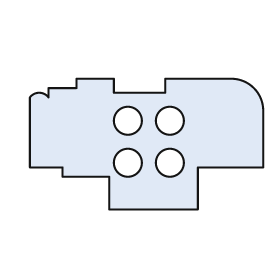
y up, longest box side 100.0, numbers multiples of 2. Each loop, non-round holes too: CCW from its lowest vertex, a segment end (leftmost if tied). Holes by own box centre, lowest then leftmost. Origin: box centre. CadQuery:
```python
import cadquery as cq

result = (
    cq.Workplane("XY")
    .moveTo(-16.0, -28.0)
    .lineTo(22.0, -28.0)
    .lineTo(22.0, -10.0)
    .lineTo(50.0, -10.0)
    .lineTo(50.0, 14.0)
    .threePointArc((46.0, 24.0), (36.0, 28.0))
    .lineTo(8.0, 28.0)
    .lineTo(8.0, 22.0)
    .lineTo(-14.0, 22.0)
    .lineTo(-14.0, 28.0)
    .lineTo(-30.0, 28.0)
    .lineTo(-30.0, 24.0)
    .lineTo(-42.0, 24.0)
    .lineTo(-42.0, 20.0)
    .threePointArc((-46.0, 22.0), (-50.0, 20.0))
    .lineTo(-50.0, -10.0)
    .lineTo(-36.0, -10.0)
    .lineTo(-36.0, -14.0)
    .lineTo(-16.0, -14.0)
    .close()
    .moveTo(-8.0, -8.0)
    .circle(6.0)
    .moveTo(10.0, -8.0)
    .circle(6.0)
    .moveTo(-8.0, 10.0)
    .circle(6.0)
    .moveTo(10.0, 10.0)
    .circle(6.0)
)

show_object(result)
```